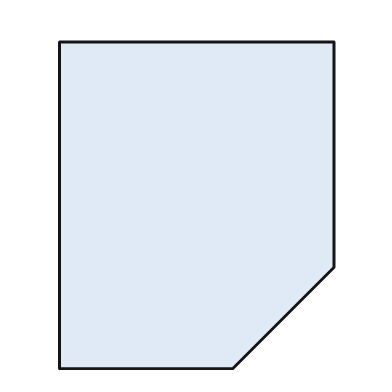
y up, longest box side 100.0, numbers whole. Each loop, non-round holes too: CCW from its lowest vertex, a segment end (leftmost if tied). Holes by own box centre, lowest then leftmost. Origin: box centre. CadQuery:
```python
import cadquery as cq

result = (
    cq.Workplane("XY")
    .moveTo(-42.0, -50.0)
    .lineTo(11.0, -50.0)
    .lineTo(42.0, -19.0)
    .lineTo(42.0, 50.0)
    .lineTo(-42.0, 50.0)
    .close()
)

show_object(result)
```